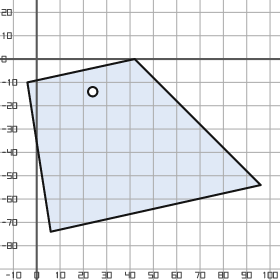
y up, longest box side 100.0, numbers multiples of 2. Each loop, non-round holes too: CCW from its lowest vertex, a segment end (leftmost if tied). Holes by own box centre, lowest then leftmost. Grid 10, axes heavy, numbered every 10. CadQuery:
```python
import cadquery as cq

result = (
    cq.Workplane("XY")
    .moveTo(6.0, -74.0)
    .lineTo(96.0, -54.0)
    .lineTo(42.0, 0.0)
    .lineTo(-4.0, -10.0)
    .close()
    .moveTo(24.0, -14.0)
    .circle(2.0)
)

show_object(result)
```